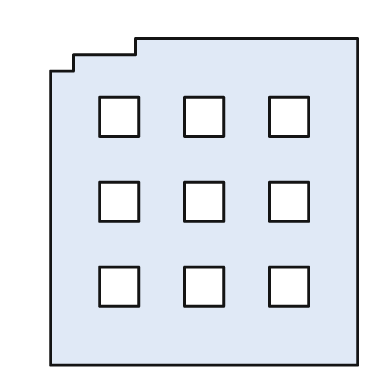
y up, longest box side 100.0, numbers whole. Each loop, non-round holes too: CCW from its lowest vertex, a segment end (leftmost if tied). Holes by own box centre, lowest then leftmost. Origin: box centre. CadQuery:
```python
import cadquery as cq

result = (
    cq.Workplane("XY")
    .moveTo(-47.0, -50.0)
    .lineTo(47.0, -50.0)
    .lineTo(47.0, 50.0)
    .lineTo(-21.0, 50.0)
    .lineTo(-21.0, 45.0)
    .lineTo(-40.0, 45.0)
    .lineTo(-40.0, 40.0)
    .lineTo(-47.0, 40.0)
    .close()
    .moveTo(-32.0, -32.0)
    .lineTo(-20.0, -32.0)
    .lineTo(-20.0, -20.0)
    .lineTo(-32.0, -20.0)
    .close()
    .moveTo(-6.0, -32.0)
    .lineTo(6.0, -32.0)
    .lineTo(6.0, -20.0)
    .lineTo(-6.0, -20.0)
    .close()
    .moveTo(20.0, -32.0)
    .lineTo(32.0, -32.0)
    .lineTo(32.0, -20.0)
    .lineTo(20.0, -20.0)
    .close()
    .moveTo(-32.0, -6.0)
    .lineTo(-20.0, -6.0)
    .lineTo(-20.0, 6.0)
    .lineTo(-32.0, 6.0)
    .close()
    .moveTo(-6.0, -6.0)
    .lineTo(6.0, -6.0)
    .lineTo(6.0, 6.0)
    .lineTo(-6.0, 6.0)
    .close()
    .moveTo(20.0, -6.0)
    .lineTo(32.0, -6.0)
    .lineTo(32.0, 6.0)
    .lineTo(20.0, 6.0)
    .close()
    .moveTo(-32.0, 20.0)
    .lineTo(-20.0, 20.0)
    .lineTo(-20.0, 32.0)
    .lineTo(-32.0, 32.0)
    .close()
    .moveTo(-6.0, 20.0)
    .lineTo(6.0, 20.0)
    .lineTo(6.0, 32.0)
    .lineTo(-6.0, 32.0)
    .close()
    .moveTo(20.0, 20.0)
    .lineTo(32.0, 20.0)
    .lineTo(32.0, 32.0)
    .lineTo(20.0, 32.0)
    .close()
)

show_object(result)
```